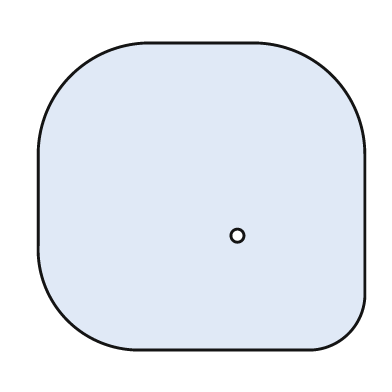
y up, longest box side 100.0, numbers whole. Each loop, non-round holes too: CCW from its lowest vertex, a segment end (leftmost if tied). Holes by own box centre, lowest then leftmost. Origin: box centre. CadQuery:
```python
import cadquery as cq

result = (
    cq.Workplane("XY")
    .moveTo(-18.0, -47.0)
    .lineTo(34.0, -47.0)
    .threePointArc((45.0, -42.0), (50.0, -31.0))
    .lineTo(50.0, 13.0)
    .threePointArc((40.0, 37.0), (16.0, 47.0))
    .lineTo(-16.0, 47.0)
    .threePointArc((-40.0, 37.0), (-50.0, 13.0))
    .lineTo(-50.0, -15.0)
    .threePointArc((-41.0, -38.0), (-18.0, -47.0))
    .close()
    .moveTo(11.0, -12.0)
    .circle(2.0)
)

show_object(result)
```